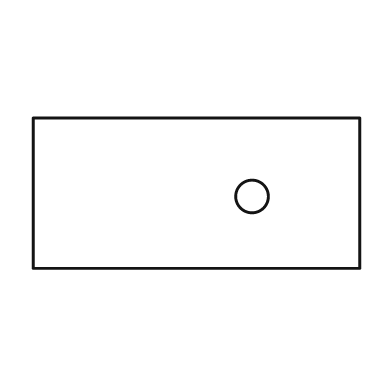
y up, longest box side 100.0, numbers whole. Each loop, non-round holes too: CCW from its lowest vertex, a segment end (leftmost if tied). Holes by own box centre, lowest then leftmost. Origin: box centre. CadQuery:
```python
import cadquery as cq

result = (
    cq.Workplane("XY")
    .moveTo(-50.0, -23.0)
    .lineTo(50.0, -23.0)
    .lineTo(50.0, 23.0)
    .lineTo(-50.0, 23.0)
    .close()
    .moveTo(17.0, -1.0)
    .circle(5.0)
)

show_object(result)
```